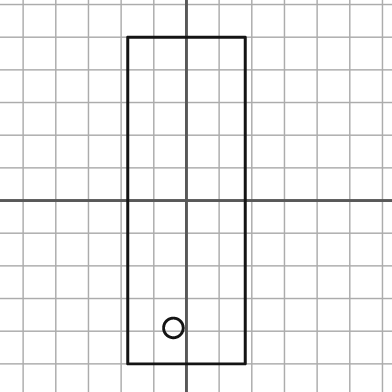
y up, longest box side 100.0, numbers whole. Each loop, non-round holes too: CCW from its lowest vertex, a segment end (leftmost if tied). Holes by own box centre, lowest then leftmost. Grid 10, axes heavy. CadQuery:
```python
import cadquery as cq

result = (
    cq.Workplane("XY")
    .moveTo(-18.0, -50.0)
    .lineTo(18.0, -50.0)
    .lineTo(18.0, 50.0)
    .lineTo(-18.0, 50.0)
    .close()
    .moveTo(-4.0, -39.0)
    .circle(3.0)
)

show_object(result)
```